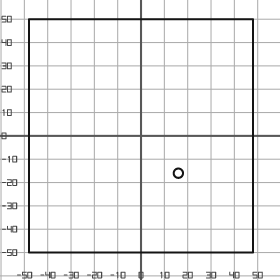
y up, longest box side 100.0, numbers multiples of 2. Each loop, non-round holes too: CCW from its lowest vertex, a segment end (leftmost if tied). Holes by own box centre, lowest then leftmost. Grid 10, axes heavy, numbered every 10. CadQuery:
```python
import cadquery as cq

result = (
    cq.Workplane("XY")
    .moveTo(-48.0, -50.0)
    .lineTo(48.0, -50.0)
    .lineTo(48.0, 50.0)
    .lineTo(-48.0, 50.0)
    .close()
    .moveTo(16.0, -16.0)
    .circle(2.0)
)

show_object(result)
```